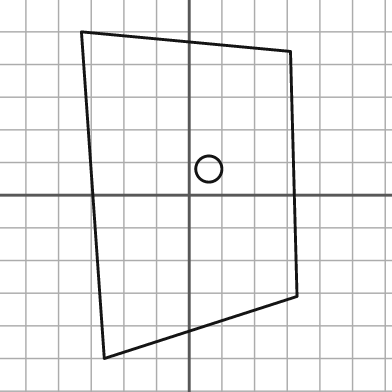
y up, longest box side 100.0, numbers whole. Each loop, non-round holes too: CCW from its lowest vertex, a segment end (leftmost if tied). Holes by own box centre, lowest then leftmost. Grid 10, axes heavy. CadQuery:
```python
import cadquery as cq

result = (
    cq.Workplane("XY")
    .moveTo(-26.0, -50.0)
    .lineTo(33.0, -31.0)
    .lineTo(31.0, 44.0)
    .lineTo(-33.0, 50.0)
    .close()
    .moveTo(6.0, 8.0)
    .circle(4.0)
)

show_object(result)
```